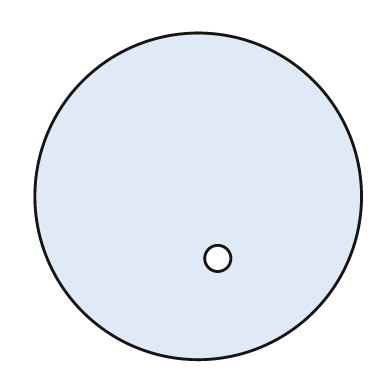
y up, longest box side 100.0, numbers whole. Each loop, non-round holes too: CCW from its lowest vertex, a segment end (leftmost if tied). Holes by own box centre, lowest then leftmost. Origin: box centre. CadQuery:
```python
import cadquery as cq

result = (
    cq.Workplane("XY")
    .moveTo(0.0, 0.0)
    .circle(50.0)
    .moveTo(6.0, -19.0)
    .circle(4.0)
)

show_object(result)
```